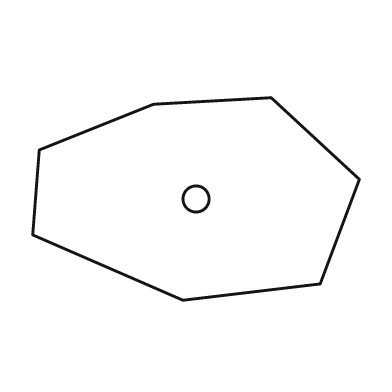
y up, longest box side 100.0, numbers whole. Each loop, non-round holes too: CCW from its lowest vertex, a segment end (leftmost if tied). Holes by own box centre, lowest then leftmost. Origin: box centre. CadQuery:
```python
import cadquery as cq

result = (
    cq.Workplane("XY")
    .moveTo(-4.0, -31.0)
    .lineTo(38.0, -26.0)
    .lineTo(50.0, 6.0)
    .lineTo(23.0, 31.0)
    .lineTo(-13.0, 29.0)
    .lineTo(-48.0, 15.0)
    .lineTo(-50.0, -11.0)
    .close()
    .moveTo(0.0, 0.0)
    .circle(4.0)
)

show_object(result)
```